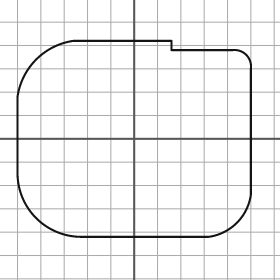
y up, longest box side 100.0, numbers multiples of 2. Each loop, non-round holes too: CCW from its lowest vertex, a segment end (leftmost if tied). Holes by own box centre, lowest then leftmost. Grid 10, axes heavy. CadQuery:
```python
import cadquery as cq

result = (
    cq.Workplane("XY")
    .moveTo(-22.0, -42.0)
    .lineTo(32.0, -42.0)
    .threePointArc((44.0, -36.0), (50.0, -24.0))
    .lineTo(50.0, 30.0)
    .threePointArc((48.0, 36.0), (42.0, 38.0))
    .lineTo(16.0, 38.0)
    .lineTo(16.0, 42.0)
    .lineTo(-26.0, 42.0)
    .threePointArc((-42.0, 34.0), (-50.0, 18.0))
    .lineTo(-50.0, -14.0)
    .threePointArc((-42.0, -34.0), (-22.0, -42.0))
    .close()
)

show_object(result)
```